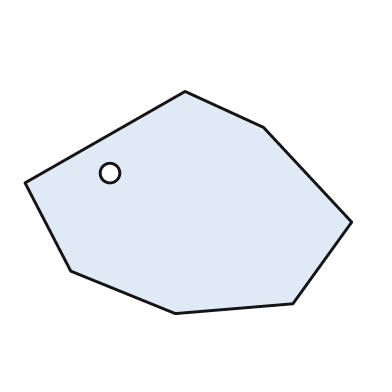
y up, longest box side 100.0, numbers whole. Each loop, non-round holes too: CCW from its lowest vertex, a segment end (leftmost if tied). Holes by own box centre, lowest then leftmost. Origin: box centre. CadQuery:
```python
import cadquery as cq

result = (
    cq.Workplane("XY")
    .moveTo(-4.0, -34.0)
    .lineTo(32.0, -31.0)
    .lineTo(50.0, -6.0)
    .lineTo(23.0, 23.0)
    .lineTo(-1.0, 34.0)
    .lineTo(-50.0, 6.0)
    .lineTo(-36.0, -21.0)
    .close()
    .moveTo(-24.0, 9.0)
    .circle(3.0)
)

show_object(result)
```